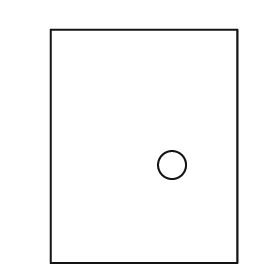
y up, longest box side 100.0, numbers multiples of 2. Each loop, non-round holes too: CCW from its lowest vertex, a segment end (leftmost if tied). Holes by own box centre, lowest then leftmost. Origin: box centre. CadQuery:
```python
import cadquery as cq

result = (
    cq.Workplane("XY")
    .moveTo(-40.0, -50.0)
    .lineTo(40.0, -50.0)
    .lineTo(40.0, 50.0)
    .lineTo(-40.0, 50.0)
    .close()
    .moveTo(12.0, -8.0)
    .circle(6.0)
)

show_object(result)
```